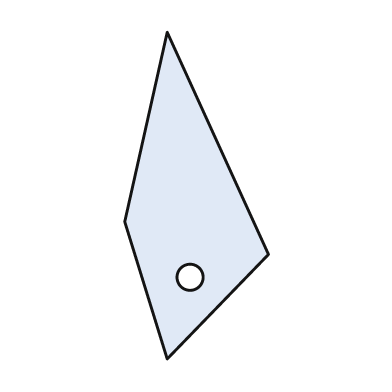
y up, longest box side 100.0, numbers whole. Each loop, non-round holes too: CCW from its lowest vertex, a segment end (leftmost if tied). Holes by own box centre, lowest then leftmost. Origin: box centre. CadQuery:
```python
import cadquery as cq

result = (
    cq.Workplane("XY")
    .moveTo(-9.0, -50.0)
    .lineTo(22.0, -18.0)
    .lineTo(-9.0, 50.0)
    .lineTo(-22.0, -8.0)
    .close()
    .moveTo(-2.0, -25.0)
    .circle(4.0)
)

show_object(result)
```